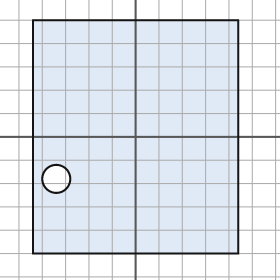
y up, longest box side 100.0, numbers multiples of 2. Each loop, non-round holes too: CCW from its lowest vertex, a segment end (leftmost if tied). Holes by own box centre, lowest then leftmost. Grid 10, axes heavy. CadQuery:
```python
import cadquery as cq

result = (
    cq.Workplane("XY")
    .moveTo(-44.0, -50.0)
    .lineTo(44.0, -50.0)
    .lineTo(44.0, 50.0)
    .lineTo(-44.0, 50.0)
    .close()
    .moveTo(-34.0, -18.0)
    .circle(6.0)
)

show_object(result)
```